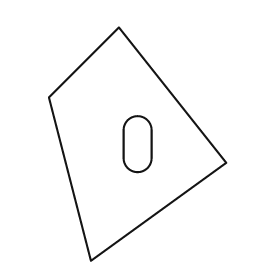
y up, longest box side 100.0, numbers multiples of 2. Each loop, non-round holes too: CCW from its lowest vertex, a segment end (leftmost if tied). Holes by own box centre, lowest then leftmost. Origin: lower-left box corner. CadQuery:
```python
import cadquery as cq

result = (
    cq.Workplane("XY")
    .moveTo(18.0, 0.0)
    .lineTo(76.0, 42.0)
    .lineTo(30.0, 100.0)
    .lineTo(0.0, 70.0)
    .close()
    .moveTo(32.0, 44.0)
    .threePointArc((38.0, 38.0), (44.0, 44.0))
    .lineTo(44.0, 56.0)
    .threePointArc((38.0, 62.0), (32.0, 56.0))
    .close()
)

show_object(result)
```